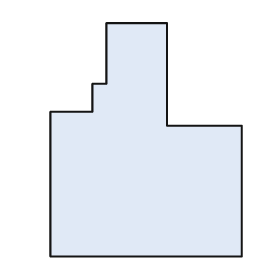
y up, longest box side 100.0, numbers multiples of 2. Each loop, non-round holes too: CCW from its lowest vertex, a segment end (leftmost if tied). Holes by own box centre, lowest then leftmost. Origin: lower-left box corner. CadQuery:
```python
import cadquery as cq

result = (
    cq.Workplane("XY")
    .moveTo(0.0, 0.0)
    .lineTo(82.0, 0.0)
    .lineTo(82.0, 56.0)
    .lineTo(50.0, 56.0)
    .lineTo(50.0, 100.0)
    .lineTo(24.0, 100.0)
    .lineTo(24.0, 74.0)
    .lineTo(18.0, 74.0)
    .lineTo(18.0, 62.0)
    .lineTo(0.0, 62.0)
    .close()
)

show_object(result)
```